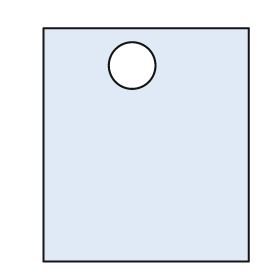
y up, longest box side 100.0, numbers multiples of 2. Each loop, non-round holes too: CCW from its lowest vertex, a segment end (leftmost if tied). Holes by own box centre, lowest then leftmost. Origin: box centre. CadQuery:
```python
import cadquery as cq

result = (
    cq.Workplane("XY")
    .moveTo(-44.0, -50.0)
    .lineTo(44.0, -50.0)
    .lineTo(44.0, 50.0)
    .lineTo(-44.0, 50.0)
    .close()
    .moveTo(-6.0, 34.0)
    .circle(10.0)
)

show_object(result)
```